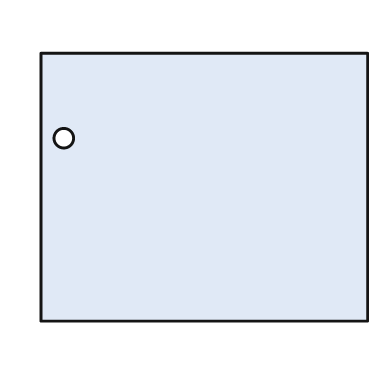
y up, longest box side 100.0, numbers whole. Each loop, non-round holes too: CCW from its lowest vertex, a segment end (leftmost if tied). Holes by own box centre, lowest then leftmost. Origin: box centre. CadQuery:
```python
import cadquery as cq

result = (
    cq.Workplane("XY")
    .moveTo(-50.0, -41.0)
    .lineTo(50.0, -41.0)
    .lineTo(50.0, 41.0)
    .lineTo(-50.0, 41.0)
    .close()
    .moveTo(-43.0, 15.0)
    .circle(3.0)
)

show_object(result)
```